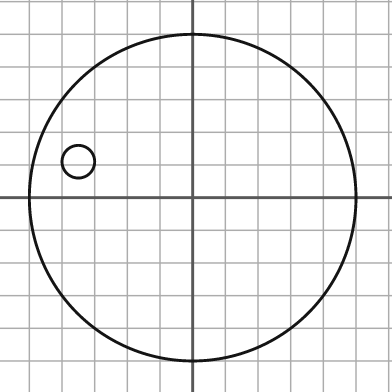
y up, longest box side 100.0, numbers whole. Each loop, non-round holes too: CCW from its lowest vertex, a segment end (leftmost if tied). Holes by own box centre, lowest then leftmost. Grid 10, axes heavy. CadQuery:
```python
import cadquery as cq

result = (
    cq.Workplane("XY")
    .moveTo(0.0, 0.0)
    .circle(50.0)
    .moveTo(-35.0, 11.0)
    .circle(5.0)
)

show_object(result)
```